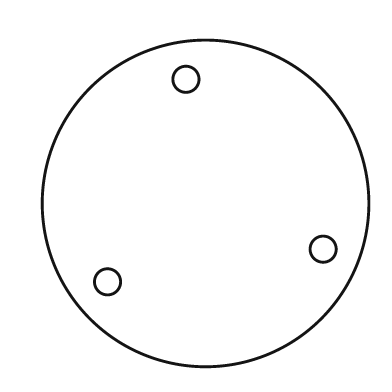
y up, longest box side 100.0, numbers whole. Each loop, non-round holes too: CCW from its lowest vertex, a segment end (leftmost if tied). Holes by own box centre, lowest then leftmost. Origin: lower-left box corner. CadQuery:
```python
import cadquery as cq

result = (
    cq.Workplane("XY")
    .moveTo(50.0, 50.0)
    .circle(50.0)
    .moveTo(20.0, 26.0)
    .circle(4.0)
    .moveTo(86.0, 36.0)
    .circle(4.0)
    .moveTo(44.0, 88.0)
    .circle(4.0)
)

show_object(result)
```